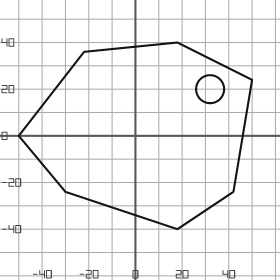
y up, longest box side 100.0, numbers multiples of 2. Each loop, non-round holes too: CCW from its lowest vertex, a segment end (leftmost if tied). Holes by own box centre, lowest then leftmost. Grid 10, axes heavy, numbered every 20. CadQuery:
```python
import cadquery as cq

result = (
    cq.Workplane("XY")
    .moveTo(18.0, -40.0)
    .lineTo(42.0, -24.0)
    .lineTo(50.0, 24.0)
    .lineTo(18.0, 40.0)
    .lineTo(-22.0, 36.0)
    .lineTo(-50.0, 0.0)
    .lineTo(-30.0, -24.0)
    .close()
    .moveTo(32.0, 20.0)
    .circle(6.0)
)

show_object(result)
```